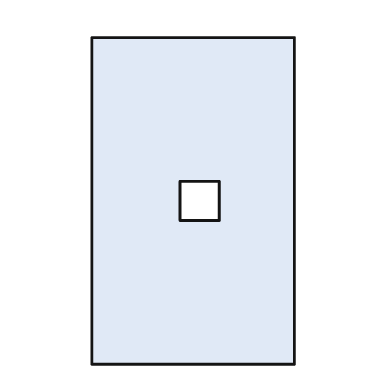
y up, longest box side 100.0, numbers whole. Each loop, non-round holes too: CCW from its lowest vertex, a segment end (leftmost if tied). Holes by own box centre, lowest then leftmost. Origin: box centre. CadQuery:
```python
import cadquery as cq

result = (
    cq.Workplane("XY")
    .moveTo(-31.0, -50.0)
    .lineTo(31.0, -50.0)
    .lineTo(31.0, 50.0)
    .lineTo(-31.0, 50.0)
    .close()
    .moveTo(-4.0, -6.0)
    .lineTo(8.0, -6.0)
    .lineTo(8.0, 6.0)
    .lineTo(-4.0, 6.0)
    .close()
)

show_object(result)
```